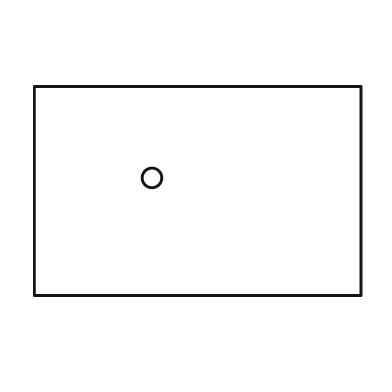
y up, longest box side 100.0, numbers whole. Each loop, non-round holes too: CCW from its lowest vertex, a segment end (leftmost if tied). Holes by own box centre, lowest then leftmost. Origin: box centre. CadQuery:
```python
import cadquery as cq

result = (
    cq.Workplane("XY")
    .moveTo(-50.0, -32.0)
    .lineTo(50.0, -32.0)
    .lineTo(50.0, 32.0)
    .lineTo(-50.0, 32.0)
    .close()
    .moveTo(-14.0, 4.0)
    .circle(3.0)
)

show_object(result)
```